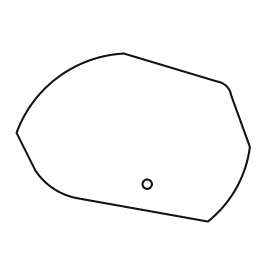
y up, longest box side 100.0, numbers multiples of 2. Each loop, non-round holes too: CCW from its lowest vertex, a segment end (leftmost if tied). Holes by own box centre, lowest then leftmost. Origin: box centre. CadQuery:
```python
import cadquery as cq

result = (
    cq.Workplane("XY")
    .moveTo(32.0, -36.0)
    .threePointArc((44.0, -22.0), (50.0, -4.0))
    .lineTo(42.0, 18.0)
    .threePointArc((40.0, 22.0), (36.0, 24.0))
    .lineTo(-4.0, 36.0)
    .threePointArc((-32.0, 26.0), (-50.0, 2.0))
    .lineTo(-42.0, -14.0)
    .threePointArc((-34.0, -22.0), (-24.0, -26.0))
    .close()
    .moveTo(6.0, -20.0)
    .circle(2.0)
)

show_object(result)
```